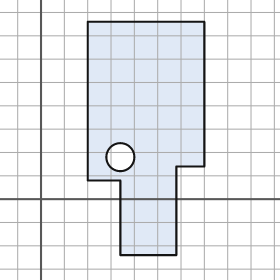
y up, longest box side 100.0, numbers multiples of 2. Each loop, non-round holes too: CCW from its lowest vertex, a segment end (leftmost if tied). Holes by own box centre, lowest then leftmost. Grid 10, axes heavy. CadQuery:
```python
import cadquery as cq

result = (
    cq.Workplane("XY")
    .moveTo(34.0, -24.0)
    .lineTo(58.0, -24.0)
    .lineTo(58.0, 14.0)
    .lineTo(70.0, 14.0)
    .lineTo(70.0, 76.0)
    .lineTo(20.0, 76.0)
    .lineTo(20.0, 8.0)
    .lineTo(34.0, 8.0)
    .close()
    .moveTo(34.0, 18.0)
    .circle(6.0)
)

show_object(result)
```